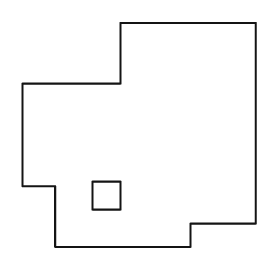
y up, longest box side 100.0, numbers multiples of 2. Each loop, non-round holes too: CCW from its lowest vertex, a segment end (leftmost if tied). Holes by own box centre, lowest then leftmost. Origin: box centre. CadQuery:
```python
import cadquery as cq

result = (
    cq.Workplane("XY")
    .moveTo(-36.0, -48.0)
    .lineTo(22.0, -48.0)
    .lineTo(22.0, -38.0)
    .lineTo(50.0, -38.0)
    .lineTo(50.0, 48.0)
    .lineTo(-8.0, 48.0)
    .lineTo(-8.0, 22.0)
    .lineTo(-50.0, 22.0)
    .lineTo(-50.0, -22.0)
    .lineTo(-36.0, -22.0)
    .close()
    .moveTo(-20.0, -32.0)
    .lineTo(-8.0, -32.0)
    .lineTo(-8.0, -20.0)
    .lineTo(-20.0, -20.0)
    .close()
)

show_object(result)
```